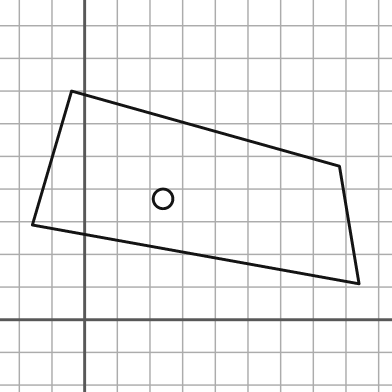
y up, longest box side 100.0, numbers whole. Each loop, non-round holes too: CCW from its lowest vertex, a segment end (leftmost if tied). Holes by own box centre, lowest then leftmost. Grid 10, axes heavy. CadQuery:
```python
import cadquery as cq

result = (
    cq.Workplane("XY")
    .moveTo(84.0, 11.0)
    .lineTo(78.0, 47.0)
    .lineTo(-4.0, 70.0)
    .lineTo(-16.0, 29.0)
    .close()
    .moveTo(24.0, 37.0)
    .circle(3.0)
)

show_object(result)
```